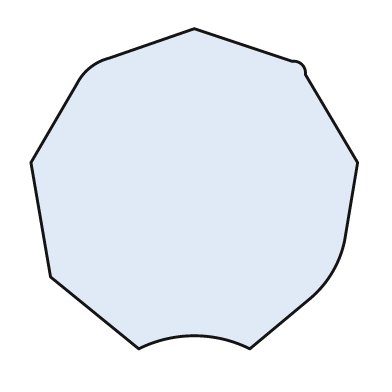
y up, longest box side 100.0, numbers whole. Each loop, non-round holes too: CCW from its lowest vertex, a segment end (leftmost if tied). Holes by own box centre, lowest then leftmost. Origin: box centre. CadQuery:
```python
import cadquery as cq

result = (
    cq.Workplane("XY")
    .moveTo(-17.0, -49.0)
    .threePointArc((0.0, -45.0), (17.0, -49.0))
    .lineTo(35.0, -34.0)
    .threePointArc((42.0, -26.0), (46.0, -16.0))
    .lineTo(50.0, 8.0)
    .lineTo(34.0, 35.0)
    .threePointArc((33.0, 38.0), (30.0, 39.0))
    .lineTo(0.0, 49.0)
    .lineTo(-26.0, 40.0)
    .threePointArc((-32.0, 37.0), (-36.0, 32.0))
    .lineTo(-50.0, 8.0)
    .lineTo(-44.0, -27.0)
    .close()
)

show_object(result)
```